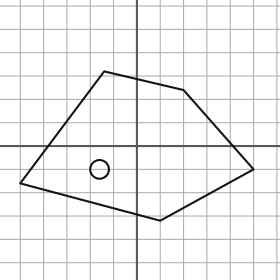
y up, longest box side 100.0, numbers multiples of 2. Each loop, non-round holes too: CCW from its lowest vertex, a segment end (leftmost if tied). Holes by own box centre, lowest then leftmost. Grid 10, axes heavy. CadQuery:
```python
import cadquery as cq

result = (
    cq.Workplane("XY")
    .moveTo(10.0, -32.0)
    .lineTo(50.0, -10.0)
    .lineTo(20.0, 24.0)
    .lineTo(-14.0, 32.0)
    .lineTo(-50.0, -16.0)
    .close()
    .moveTo(-16.0, -10.0)
    .circle(4.0)
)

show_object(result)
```